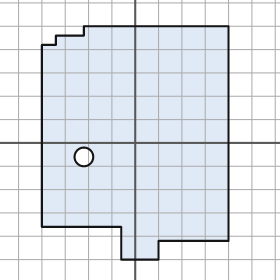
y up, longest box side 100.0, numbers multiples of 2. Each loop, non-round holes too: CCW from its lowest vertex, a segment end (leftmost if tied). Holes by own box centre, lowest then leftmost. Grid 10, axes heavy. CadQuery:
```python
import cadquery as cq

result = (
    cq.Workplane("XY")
    .moveTo(-6.0, -50.0)
    .lineTo(10.0, -50.0)
    .lineTo(10.0, -42.0)
    .lineTo(40.0, -42.0)
    .lineTo(40.0, 50.0)
    .lineTo(-22.0, 50.0)
    .lineTo(-22.0, 46.0)
    .lineTo(-34.0, 46.0)
    .lineTo(-34.0, 42.0)
    .lineTo(-40.0, 42.0)
    .lineTo(-40.0, -36.0)
    .lineTo(-6.0, -36.0)
    .close()
    .moveTo(-22.0, -6.0)
    .circle(4.0)
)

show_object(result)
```